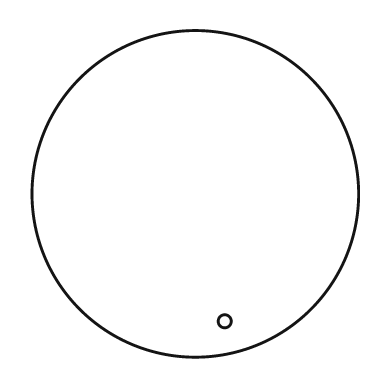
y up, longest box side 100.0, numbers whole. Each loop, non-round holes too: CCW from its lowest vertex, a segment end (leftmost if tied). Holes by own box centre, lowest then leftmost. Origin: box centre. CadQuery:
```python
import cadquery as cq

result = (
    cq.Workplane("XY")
    .moveTo(0.0, 0.0)
    .circle(50.0)
    .moveTo(9.0, -39.0)
    .circle(2.0)
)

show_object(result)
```